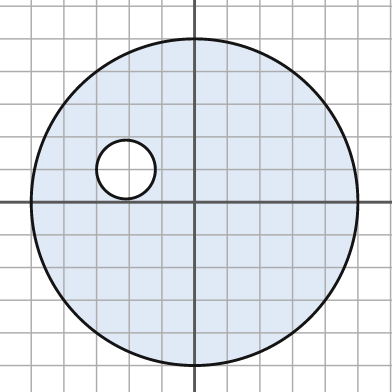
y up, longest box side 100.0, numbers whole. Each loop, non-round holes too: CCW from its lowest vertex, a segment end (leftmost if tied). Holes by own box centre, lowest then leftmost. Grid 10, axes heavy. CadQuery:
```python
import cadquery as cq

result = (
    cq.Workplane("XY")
    .moveTo(0.0, 0.0)
    .circle(50.0)
    .moveTo(-21.0, 10.0)
    .circle(9.0)
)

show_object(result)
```